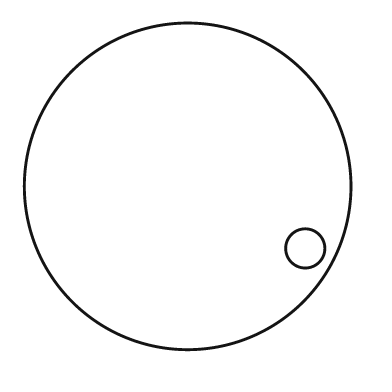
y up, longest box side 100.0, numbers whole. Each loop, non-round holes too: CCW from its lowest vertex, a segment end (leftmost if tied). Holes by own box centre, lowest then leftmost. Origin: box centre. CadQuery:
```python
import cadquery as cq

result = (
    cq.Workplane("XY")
    .moveTo(0.0, 0.0)
    .circle(50.0)
    .moveTo(36.0, -19.0)
    .circle(6.0)
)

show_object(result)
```